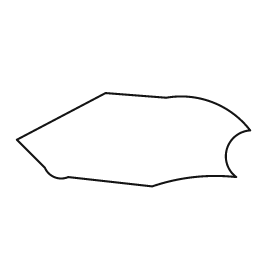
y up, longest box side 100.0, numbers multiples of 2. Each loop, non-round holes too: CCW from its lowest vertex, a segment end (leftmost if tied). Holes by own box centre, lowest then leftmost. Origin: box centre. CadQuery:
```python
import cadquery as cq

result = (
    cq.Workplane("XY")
    .moveTo(8.0, -20.0)
    .threePointArc((26.0, -16.0), (44.0, -16.0))
    .threePointArc((40.0, -4.0), (50.0, 4.0))
    .threePointArc((34.0, 16.0), (14.0, 18.0))
    .lineTo(-12.0, 20.0)
    .lineTo(-50.0, 0.0)
    .lineTo(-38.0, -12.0)
    .threePointArc((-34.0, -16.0), (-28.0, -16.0))
    .close()
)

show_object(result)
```